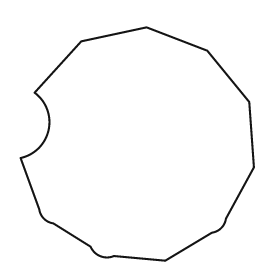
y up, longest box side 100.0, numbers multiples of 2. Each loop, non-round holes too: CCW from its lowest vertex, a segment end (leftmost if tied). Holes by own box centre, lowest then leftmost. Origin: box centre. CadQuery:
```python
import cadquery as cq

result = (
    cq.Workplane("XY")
    .moveTo(12.0, -50.0)
    .lineTo(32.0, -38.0)
    .threePointArc((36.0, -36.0), (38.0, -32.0))
    .lineTo(50.0, -10.0)
    .lineTo(48.0, 18.0)
    .lineTo(30.0, 40.0)
    .lineTo(4.0, 50.0)
    .lineTo(-24.0, 44.0)
    .lineTo(-44.0, 22.0)
    .threePointArc((-38.0, 6.0), (-50.0, -6.0))
    .lineTo(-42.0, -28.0)
    .threePointArc((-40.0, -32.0), (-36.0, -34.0))
    .lineTo(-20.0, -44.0)
    .threePointArc((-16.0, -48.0), (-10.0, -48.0))
    .close()
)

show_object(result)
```